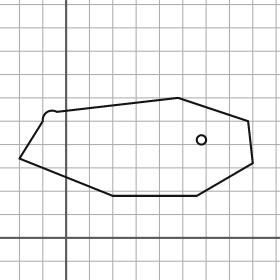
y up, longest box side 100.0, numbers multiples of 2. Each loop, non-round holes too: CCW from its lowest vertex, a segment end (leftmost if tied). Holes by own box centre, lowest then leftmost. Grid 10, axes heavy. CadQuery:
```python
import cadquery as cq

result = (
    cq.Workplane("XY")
    .moveTo(20.0, 18.0)
    .lineTo(56.0, 18.0)
    .lineTo(80.0, 32.0)
    .lineTo(78.0, 50.0)
    .lineTo(48.0, 60.0)
    .lineTo(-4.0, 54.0)
    .threePointArc((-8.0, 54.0), (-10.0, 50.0))
    .lineTo(-20.0, 34.0)
    .close()
    .moveTo(58.0, 42.0)
    .circle(2.0)
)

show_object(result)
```